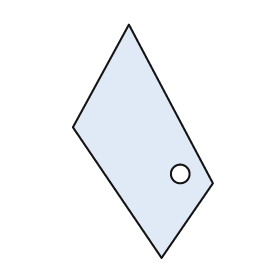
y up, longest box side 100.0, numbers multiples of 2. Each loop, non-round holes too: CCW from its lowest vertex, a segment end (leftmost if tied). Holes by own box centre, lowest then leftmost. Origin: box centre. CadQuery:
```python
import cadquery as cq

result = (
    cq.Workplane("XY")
    .moveTo(8.0, -50.0)
    .lineTo(30.0, -18.0)
    .lineTo(-6.0, 50.0)
    .lineTo(-30.0, 6.0)
    .close()
    .moveTo(16.0, -14.0)
    .circle(4.0)
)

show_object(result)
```